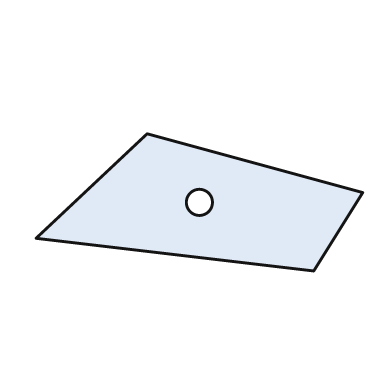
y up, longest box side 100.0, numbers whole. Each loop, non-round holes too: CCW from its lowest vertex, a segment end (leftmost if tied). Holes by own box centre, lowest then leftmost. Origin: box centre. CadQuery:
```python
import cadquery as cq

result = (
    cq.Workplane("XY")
    .moveTo(35.0, -21.0)
    .lineTo(50.0, 3.0)
    .lineTo(-16.0, 21.0)
    .lineTo(-50.0, -11.0)
    .close()
    .moveTo(0.0, 0.0)
    .circle(4.0)
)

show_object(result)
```